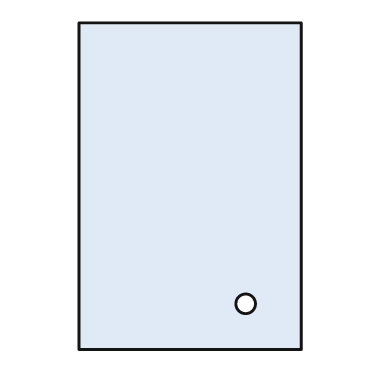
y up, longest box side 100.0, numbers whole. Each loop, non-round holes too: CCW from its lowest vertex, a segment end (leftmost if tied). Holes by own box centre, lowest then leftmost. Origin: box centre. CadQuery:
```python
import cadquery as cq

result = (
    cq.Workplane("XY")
    .moveTo(-34.0, -50.0)
    .lineTo(34.0, -50.0)
    .lineTo(34.0, 50.0)
    .lineTo(-34.0, 50.0)
    .close()
    .moveTo(17.0, -36.0)
    .circle(3.0)
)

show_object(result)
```